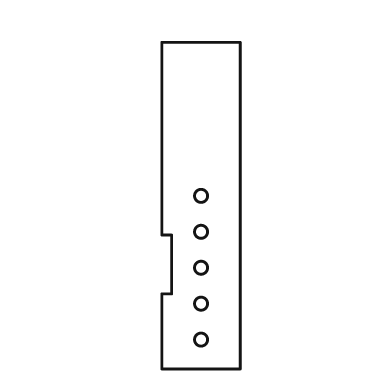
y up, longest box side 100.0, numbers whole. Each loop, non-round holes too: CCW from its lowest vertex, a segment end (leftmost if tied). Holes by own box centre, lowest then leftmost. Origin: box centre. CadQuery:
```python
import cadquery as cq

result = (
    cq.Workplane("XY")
    .moveTo(-12.0, -50.0)
    .lineTo(12.0, -50.0)
    .lineTo(12.0, 50.0)
    .lineTo(-12.0, 50.0)
    .lineTo(-12.0, -9.0)
    .lineTo(-9.0, -9.0)
    .lineTo(-9.0, -27.0)
    .lineTo(-12.0, -27.0)
    .close()
    .moveTo(0.0, -41.0)
    .circle(2.0)
    .moveTo(0.0, -30.0)
    .circle(2.0)
    .moveTo(0.0, -19.0)
    .circle(2.0)
    .moveTo(0.0, -8.0)
    .circle(2.0)
    .moveTo(0.0, 3.0)
    .circle(2.0)
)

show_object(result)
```